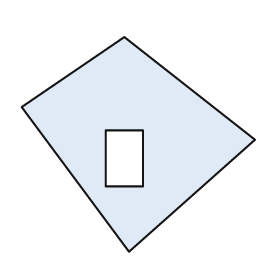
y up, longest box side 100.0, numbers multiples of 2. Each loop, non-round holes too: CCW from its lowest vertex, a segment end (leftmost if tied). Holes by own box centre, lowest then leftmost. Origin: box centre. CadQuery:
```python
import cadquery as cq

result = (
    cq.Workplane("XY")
    .moveTo(-4.0, -46.0)
    .lineTo(50.0, 2.0)
    .lineTo(-6.0, 46.0)
    .lineTo(-50.0, 16.0)
    .close()
    .moveTo(-14.0, -18.0)
    .lineTo(2.0, -18.0)
    .lineTo(2.0, 6.0)
    .lineTo(-14.0, 6.0)
    .close()
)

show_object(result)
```